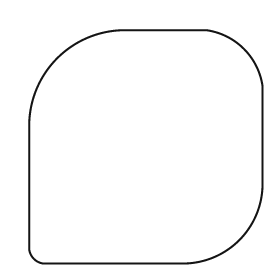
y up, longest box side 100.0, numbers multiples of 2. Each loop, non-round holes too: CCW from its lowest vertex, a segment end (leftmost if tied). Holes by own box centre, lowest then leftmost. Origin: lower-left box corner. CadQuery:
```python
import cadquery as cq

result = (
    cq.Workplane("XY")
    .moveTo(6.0, 0.0)
    .lineTo(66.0, 0.0)
    .threePointArc((90.0, 10.0), (100.0, 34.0))
    .lineTo(100.0, 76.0)
    .threePointArc((92.0, 92.0), (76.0, 100.0))
    .lineTo(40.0, 100.0)
    .threePointArc((12.0, 88.0), (0.0, 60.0))
    .lineTo(0.0, 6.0)
    .threePointArc((2.0, 2.0), (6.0, 0.0))
    .close()
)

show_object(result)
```